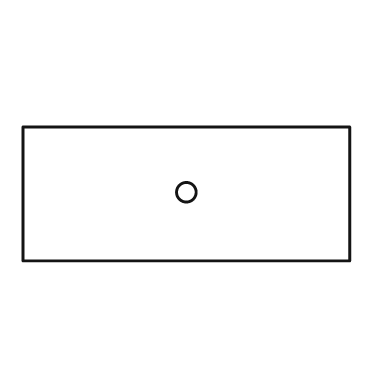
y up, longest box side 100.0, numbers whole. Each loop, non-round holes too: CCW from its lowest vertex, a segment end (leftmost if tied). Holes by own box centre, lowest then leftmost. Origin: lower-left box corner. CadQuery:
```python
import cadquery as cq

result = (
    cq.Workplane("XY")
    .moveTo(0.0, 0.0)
    .lineTo(100.0, 0.0)
    .lineTo(100.0, 41.0)
    .lineTo(0.0, 41.0)
    .close()
    .moveTo(50.0, 21.0)
    .circle(3.0)
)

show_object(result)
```